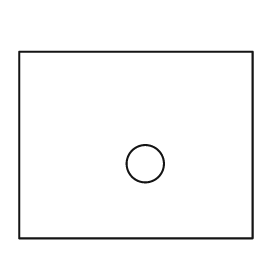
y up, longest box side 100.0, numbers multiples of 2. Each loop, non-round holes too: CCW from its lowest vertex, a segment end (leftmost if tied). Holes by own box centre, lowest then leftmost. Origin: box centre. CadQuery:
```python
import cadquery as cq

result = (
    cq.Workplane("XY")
    .moveTo(-50.0, -40.0)
    .lineTo(50.0, -40.0)
    .lineTo(50.0, 40.0)
    .lineTo(-50.0, 40.0)
    .close()
    .moveTo(4.0, -8.0)
    .circle(8.0)
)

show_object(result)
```